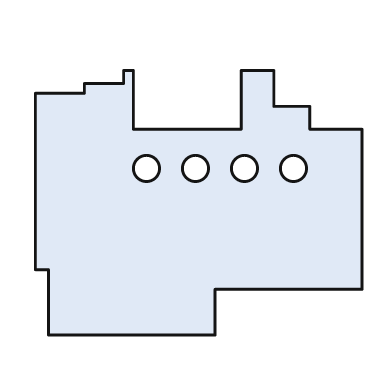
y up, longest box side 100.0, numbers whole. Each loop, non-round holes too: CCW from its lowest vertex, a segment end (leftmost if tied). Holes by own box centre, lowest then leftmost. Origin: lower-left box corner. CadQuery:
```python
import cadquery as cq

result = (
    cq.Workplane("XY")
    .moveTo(4.0, 0.0)
    .lineTo(55.0, 0.0)
    .lineTo(55.0, 14.0)
    .lineTo(100.0, 14.0)
    .lineTo(100.0, 63.0)
    .lineTo(84.0, 63.0)
    .lineTo(84.0, 70.0)
    .lineTo(73.0, 70.0)
    .lineTo(73.0, 81.0)
    .lineTo(63.0, 81.0)
    .lineTo(63.0, 63.0)
    .lineTo(30.0, 63.0)
    .lineTo(30.0, 81.0)
    .lineTo(27.0, 81.0)
    .lineTo(27.0, 77.0)
    .lineTo(15.0, 77.0)
    .lineTo(15.0, 74.0)
    .lineTo(0.0, 74.0)
    .lineTo(0.0, 20.0)
    .lineTo(4.0, 20.0)
    .close()
    .moveTo(34.0, 51.0)
    .circle(4.0)
    .moveTo(49.0, 51.0)
    .circle(4.0)
    .moveTo(64.0, 51.0)
    .circle(4.0)
    .moveTo(79.0, 51.0)
    .circle(4.0)
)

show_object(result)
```